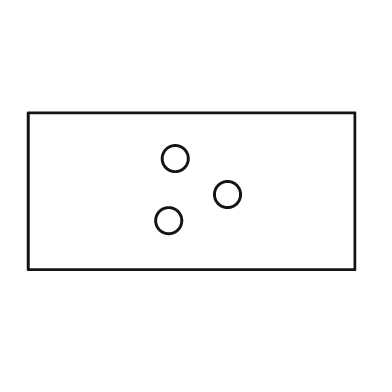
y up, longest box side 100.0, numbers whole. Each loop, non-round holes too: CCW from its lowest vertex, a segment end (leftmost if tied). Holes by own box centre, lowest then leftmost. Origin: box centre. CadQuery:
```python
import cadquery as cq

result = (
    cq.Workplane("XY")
    .moveTo(-50.0, -24.0)
    .lineTo(50.0, -24.0)
    .lineTo(50.0, 24.0)
    .lineTo(-50.0, 24.0)
    .close()
    .moveTo(-7.0, -9.0)
    .circle(4.0)
    .moveTo(11.0, -1.0)
    .circle(4.0)
    .moveTo(-5.0, 10.0)
    .circle(4.0)
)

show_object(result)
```